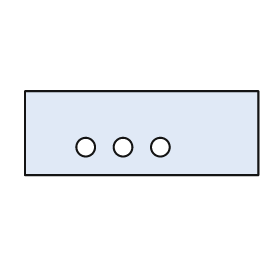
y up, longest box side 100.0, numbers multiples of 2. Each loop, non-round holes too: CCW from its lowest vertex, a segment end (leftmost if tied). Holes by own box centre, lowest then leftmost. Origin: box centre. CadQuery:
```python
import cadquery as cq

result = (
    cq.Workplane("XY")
    .moveTo(-50.0, -18.0)
    .lineTo(50.0, -18.0)
    .lineTo(50.0, 18.0)
    .lineTo(-50.0, 18.0)
    .close()
    .moveTo(-24.0, -6.0)
    .circle(4.0)
    .moveTo(-8.0, -6.0)
    .circle(4.0)
    .moveTo(8.0, -6.0)
    .circle(4.0)
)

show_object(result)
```